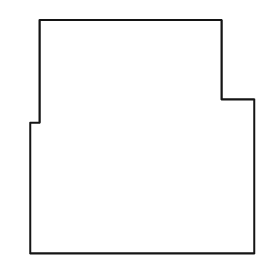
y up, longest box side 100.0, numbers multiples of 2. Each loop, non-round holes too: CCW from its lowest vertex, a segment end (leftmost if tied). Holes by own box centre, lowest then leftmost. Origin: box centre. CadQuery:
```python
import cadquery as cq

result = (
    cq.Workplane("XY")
    .moveTo(-48.0, -50.0)
    .lineTo(48.0, -50.0)
    .lineTo(48.0, 16.0)
    .lineTo(34.0, 16.0)
    .lineTo(34.0, 50.0)
    .lineTo(-44.0, 50.0)
    .lineTo(-44.0, 6.0)
    .lineTo(-48.0, 6.0)
    .close()
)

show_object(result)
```